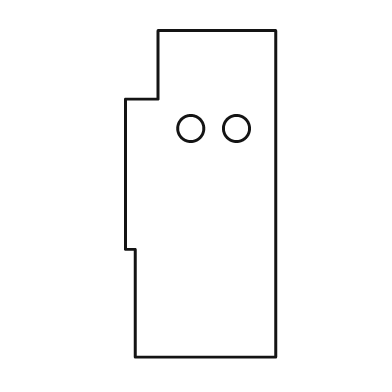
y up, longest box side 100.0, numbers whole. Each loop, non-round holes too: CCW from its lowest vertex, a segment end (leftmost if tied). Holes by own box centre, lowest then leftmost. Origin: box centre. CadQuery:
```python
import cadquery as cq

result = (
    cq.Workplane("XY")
    .moveTo(-20.0, -50.0)
    .lineTo(23.0, -50.0)
    .lineTo(23.0, 50.0)
    .lineTo(-13.0, 50.0)
    .lineTo(-13.0, 29.0)
    .lineTo(-23.0, 29.0)
    .lineTo(-23.0, -17.0)
    .lineTo(-20.0, -17.0)
    .close()
    .moveTo(-3.0, 20.0)
    .circle(4.0)
    .moveTo(11.0, 20.0)
    .circle(4.0)
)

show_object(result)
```